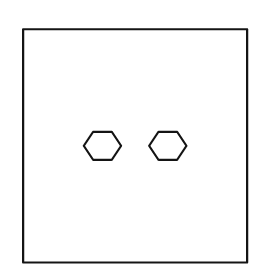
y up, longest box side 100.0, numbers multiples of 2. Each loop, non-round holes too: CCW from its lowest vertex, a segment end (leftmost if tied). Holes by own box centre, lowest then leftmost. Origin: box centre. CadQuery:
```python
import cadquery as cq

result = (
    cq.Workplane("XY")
    .moveTo(-48.0, -50.0)
    .lineTo(48.0, -50.0)
    .lineTo(48.0, 50.0)
    .lineTo(-48.0, 50.0)
    .close()
    .moveTo(-18.0, -6.0)
    .lineTo(-10.0, -6.0)
    .lineTo(-6.0, 0.0)
    .lineTo(-10.0, 6.0)
    .lineTo(-18.0, 6.0)
    .lineTo(-22.0, 0.0)
    .close()
    .moveTo(10.0, -6.0)
    .lineTo(18.0, -6.0)
    .lineTo(22.0, 0.0)
    .lineTo(18.0, 6.0)
    .lineTo(10.0, 6.0)
    .lineTo(6.0, 0.0)
    .close()
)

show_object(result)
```